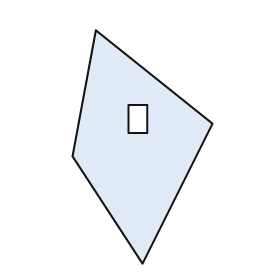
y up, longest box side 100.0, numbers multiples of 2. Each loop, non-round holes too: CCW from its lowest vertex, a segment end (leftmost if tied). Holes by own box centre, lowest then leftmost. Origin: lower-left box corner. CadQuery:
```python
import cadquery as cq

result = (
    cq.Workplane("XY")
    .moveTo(30.0, 0.0)
    .lineTo(60.0, 60.0)
    .lineTo(10.0, 100.0)
    .lineTo(0.0, 46.0)
    .close()
    .moveTo(24.0, 56.0)
    .lineTo(32.0, 56.0)
    .lineTo(32.0, 68.0)
    .lineTo(24.0, 68.0)
    .close()
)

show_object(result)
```